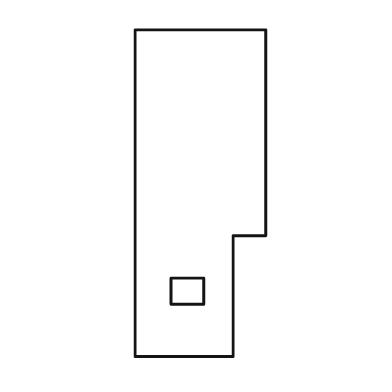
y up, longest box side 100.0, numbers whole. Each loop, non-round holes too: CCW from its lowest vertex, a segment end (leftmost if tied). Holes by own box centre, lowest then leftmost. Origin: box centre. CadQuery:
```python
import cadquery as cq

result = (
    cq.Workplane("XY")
    .moveTo(-20.0, -50.0)
    .lineTo(10.0, -50.0)
    .lineTo(10.0, -13.0)
    .lineTo(20.0, -13.0)
    .lineTo(20.0, 50.0)
    .lineTo(-20.0, 50.0)
    .close()
    .moveTo(-9.0, -34.0)
    .lineTo(1.0, -34.0)
    .lineTo(1.0, -26.0)
    .lineTo(-9.0, -26.0)
    .close()
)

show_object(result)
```